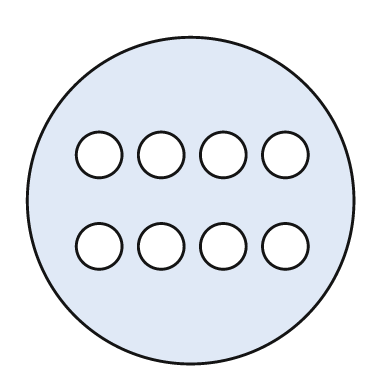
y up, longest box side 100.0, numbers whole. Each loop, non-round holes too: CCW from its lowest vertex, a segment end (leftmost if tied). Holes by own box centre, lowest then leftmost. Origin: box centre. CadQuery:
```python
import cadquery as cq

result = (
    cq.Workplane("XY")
    .moveTo(0.0, 0.0)
    .circle(50.0)
    .moveTo(-28.0, -14.0)
    .circle(7.0)
    .moveTo(-9.0, -14.0)
    .circle(7.0)
    .moveTo(10.0, -14.0)
    .circle(7.0)
    .moveTo(29.0, -14.0)
    .circle(7.0)
    .moveTo(-28.0, 14.0)
    .circle(7.0)
    .moveTo(-9.0, 14.0)
    .circle(7.0)
    .moveTo(10.0, 14.0)
    .circle(7.0)
    .moveTo(29.0, 14.0)
    .circle(7.0)
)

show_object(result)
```